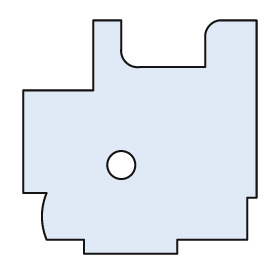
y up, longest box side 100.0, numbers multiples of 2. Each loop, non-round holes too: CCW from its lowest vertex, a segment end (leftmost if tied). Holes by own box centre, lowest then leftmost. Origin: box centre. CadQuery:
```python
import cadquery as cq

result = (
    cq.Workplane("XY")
    .moveTo(-24.0, -50.0)
    .lineTo(16.0, -50.0)
    .lineTo(16.0, -44.0)
    .lineTo(46.0, -44.0)
    .lineTo(46.0, -26.0)
    .lineTo(50.0, -26.0)
    .lineTo(50.0, 50.0)
    .lineTo(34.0, 50.0)
    .threePointArc((30.0, 48.0), (28.0, 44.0))
    .lineTo(28.0, 30.0)
    .lineTo(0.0, 30.0)
    .threePointArc((-6.0, 32.0), (-8.0, 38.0))
    .lineTo(-8.0, 50.0)
    .lineTo(-20.0, 50.0)
    .lineTo(-20.0, 20.0)
    .lineTo(-50.0, 20.0)
    .lineTo(-50.0, -24.0)
    .lineTo(-40.0, -24.0)
    .threePointArc((-42.0, -34.0), (-40.0, -44.0))
    .lineTo(-24.0, -44.0)
    .close()
    .moveTo(-8.0, -12.0)
    .circle(6.0)
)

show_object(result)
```